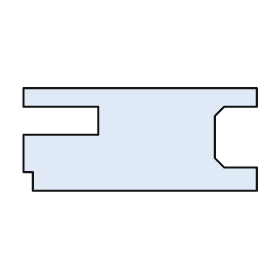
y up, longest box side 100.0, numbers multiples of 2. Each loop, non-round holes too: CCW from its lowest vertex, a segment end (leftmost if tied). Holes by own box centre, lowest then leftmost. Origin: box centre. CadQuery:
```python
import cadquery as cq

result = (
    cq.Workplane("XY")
    .moveTo(-46.0, -22.0)
    .lineTo(50.0, -22.0)
    .lineTo(50.0, -12.0)
    .lineTo(36.0, -12.0)
    .lineTo(32.0, -8.0)
    .lineTo(32.0, 10.0)
    .lineTo(36.0, 14.0)
    .lineTo(50.0, 14.0)
    .lineTo(50.0, 22.0)
    .lineTo(-50.0, 22.0)
    .lineTo(-50.0, 14.0)
    .lineTo(-18.0, 14.0)
    .lineTo(-18.0, 2.0)
    .lineTo(-50.0, 2.0)
    .lineTo(-50.0, -14.0)
    .lineTo(-46.0, -14.0)
    .close()
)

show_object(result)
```